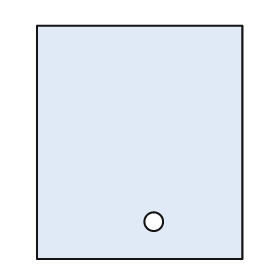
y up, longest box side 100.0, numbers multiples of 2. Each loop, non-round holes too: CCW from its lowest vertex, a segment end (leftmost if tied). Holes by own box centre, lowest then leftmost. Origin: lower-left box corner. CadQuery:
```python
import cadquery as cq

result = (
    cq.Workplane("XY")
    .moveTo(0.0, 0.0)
    .lineTo(88.0, 0.0)
    .lineTo(88.0, 100.0)
    .lineTo(0.0, 100.0)
    .close()
    .moveTo(50.0, 16.0)
    .circle(4.0)
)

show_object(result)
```